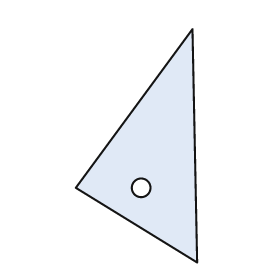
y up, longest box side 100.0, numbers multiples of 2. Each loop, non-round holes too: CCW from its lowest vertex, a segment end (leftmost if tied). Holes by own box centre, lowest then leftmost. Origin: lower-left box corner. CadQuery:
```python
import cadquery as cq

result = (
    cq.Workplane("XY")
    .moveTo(52.0, 0.0)
    .lineTo(50.0, 100.0)
    .lineTo(0.0, 32.0)
    .close()
    .moveTo(28.0, 32.0)
    .circle(4.0)
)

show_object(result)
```